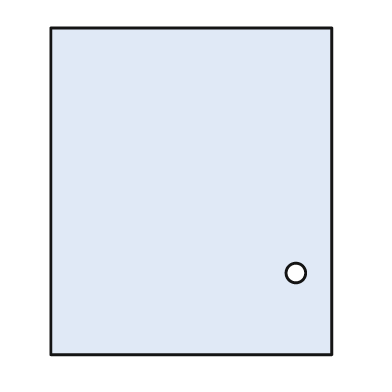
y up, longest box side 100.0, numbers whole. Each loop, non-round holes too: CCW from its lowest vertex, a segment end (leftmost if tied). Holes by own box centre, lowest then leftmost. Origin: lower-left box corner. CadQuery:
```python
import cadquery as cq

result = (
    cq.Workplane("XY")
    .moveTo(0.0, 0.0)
    .lineTo(86.0, 0.0)
    .lineTo(86.0, 100.0)
    .lineTo(0.0, 100.0)
    .close()
    .moveTo(75.0, 25.0)
    .circle(3.0)
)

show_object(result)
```